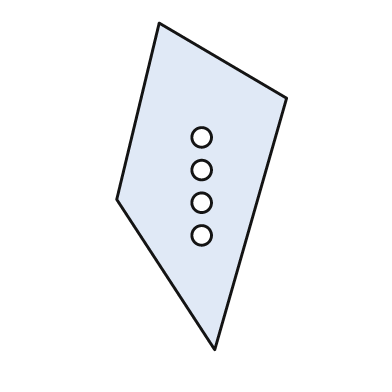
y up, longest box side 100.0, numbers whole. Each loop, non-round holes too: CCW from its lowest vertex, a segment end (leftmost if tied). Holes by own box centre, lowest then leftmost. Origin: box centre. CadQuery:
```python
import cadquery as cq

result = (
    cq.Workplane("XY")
    .moveTo(4.0, -50.0)
    .lineTo(26.0, 27.0)
    .lineTo(-13.0, 50.0)
    .lineTo(-26.0, -4.0)
    .close()
    .moveTo(0.0, -15.0)
    .circle(3.0)
    .moveTo(0.0, -5.0)
    .circle(3.0)
    .moveTo(0.0, 5.0)
    .circle(3.0)
    .moveTo(0.0, 15.0)
    .circle(3.0)
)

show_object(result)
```